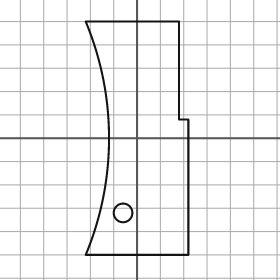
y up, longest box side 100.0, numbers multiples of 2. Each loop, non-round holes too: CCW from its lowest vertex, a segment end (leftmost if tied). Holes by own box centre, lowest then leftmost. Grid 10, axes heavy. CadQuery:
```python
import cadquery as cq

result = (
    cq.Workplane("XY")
    .moveTo(-22.0, -50.0)
    .lineTo(22.0, -50.0)
    .lineTo(22.0, 8.0)
    .lineTo(18.0, 8.0)
    .lineTo(18.0, 50.0)
    .lineTo(-22.0, 50.0)
    .threePointArc((-12.0, 0.0), (-22.0, -50.0))
    .close()
    .moveTo(-6.0, -32.0)
    .circle(4.0)
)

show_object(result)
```